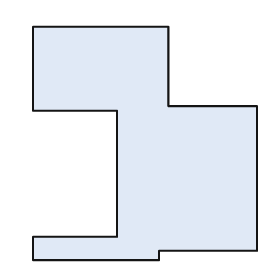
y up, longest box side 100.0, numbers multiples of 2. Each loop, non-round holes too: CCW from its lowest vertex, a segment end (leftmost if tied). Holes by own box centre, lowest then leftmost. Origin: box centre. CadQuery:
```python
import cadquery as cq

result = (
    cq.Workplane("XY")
    .moveTo(-48.0, -50.0)
    .lineTo(6.0, -50.0)
    .lineTo(6.0, -46.0)
    .lineTo(48.0, -46.0)
    .lineTo(48.0, 16.0)
    .lineTo(10.0, 16.0)
    .lineTo(10.0, 50.0)
    .lineTo(-48.0, 50.0)
    .lineTo(-48.0, 14.0)
    .lineTo(-12.0, 14.0)
    .lineTo(-12.0, -40.0)
    .lineTo(-48.0, -40.0)
    .close()
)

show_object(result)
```